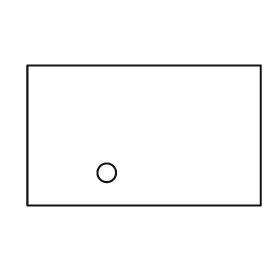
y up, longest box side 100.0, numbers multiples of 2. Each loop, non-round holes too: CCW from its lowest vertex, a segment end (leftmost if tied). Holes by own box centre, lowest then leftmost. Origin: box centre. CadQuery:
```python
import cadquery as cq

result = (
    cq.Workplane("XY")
    .moveTo(-50.0, -30.0)
    .lineTo(50.0, -30.0)
    .lineTo(50.0, 30.0)
    .lineTo(-50.0, 30.0)
    .close()
    .moveTo(-16.0, -16.0)
    .circle(4.0)
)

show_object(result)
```